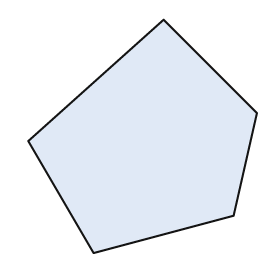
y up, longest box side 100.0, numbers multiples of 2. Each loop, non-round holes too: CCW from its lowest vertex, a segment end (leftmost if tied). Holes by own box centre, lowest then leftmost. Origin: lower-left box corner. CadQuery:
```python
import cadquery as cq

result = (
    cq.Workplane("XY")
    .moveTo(28.0, 0.0)
    .lineTo(88.0, 16.0)
    .lineTo(98.0, 60.0)
    .lineTo(58.0, 100.0)
    .lineTo(0.0, 48.0)
    .close()
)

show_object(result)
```